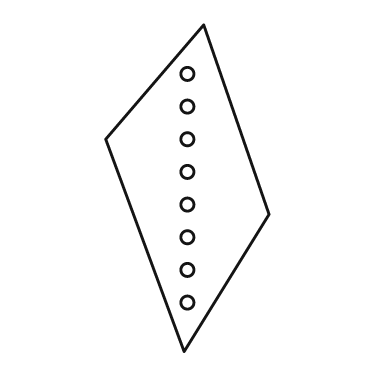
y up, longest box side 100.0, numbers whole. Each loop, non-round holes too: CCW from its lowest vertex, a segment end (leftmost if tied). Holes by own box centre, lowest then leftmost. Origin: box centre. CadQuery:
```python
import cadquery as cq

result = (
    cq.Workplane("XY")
    .moveTo(-1.0, -50.0)
    .lineTo(25.0, -8.0)
    .lineTo(5.0, 50.0)
    .lineTo(-25.0, 15.0)
    .close()
    .moveTo(0.0, -35.0)
    .circle(2.0)
    .moveTo(0.0, -25.0)
    .circle(2.0)
    .moveTo(0.0, -15.0)
    .circle(2.0)
    .moveTo(0.0, -5.0)
    .circle(2.0)
    .moveTo(0.0, 5.0)
    .circle(2.0)
    .moveTo(0.0, 15.0)
    .circle(2.0)
    .moveTo(0.0, 25.0)
    .circle(2.0)
    .moveTo(0.0, 35.0)
    .circle(2.0)
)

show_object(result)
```